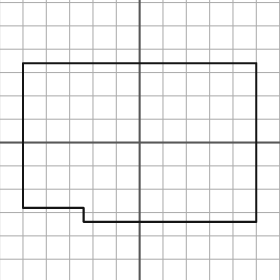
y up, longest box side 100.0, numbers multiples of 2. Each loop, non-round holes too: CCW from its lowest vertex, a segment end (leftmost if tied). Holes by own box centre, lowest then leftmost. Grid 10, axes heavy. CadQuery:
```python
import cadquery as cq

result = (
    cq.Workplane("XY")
    .moveTo(-24.0, -34.0)
    .lineTo(50.0, -34.0)
    .lineTo(50.0, 34.0)
    .lineTo(-50.0, 34.0)
    .lineTo(-50.0, -28.0)
    .lineTo(-24.0, -28.0)
    .close()
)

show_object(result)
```